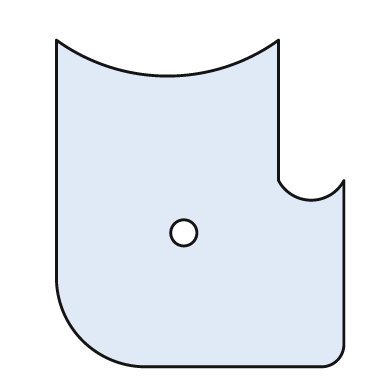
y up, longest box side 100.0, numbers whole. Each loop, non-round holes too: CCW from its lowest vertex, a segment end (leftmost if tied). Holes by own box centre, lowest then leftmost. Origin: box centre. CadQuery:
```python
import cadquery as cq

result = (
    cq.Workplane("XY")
    .moveTo(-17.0, -50.0)
    .lineTo(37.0, -50.0)
    .threePointArc((42.0, -48.0), (44.0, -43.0))
    .lineTo(44.0, 7.0)
    .threePointArc((34.0, 1.0), (24.0, 7.0))
    .lineTo(24.0, 50.0)
    .threePointArc((-10.0, 39.0), (-44.0, 50.0))
    .lineTo(-44.0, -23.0)
    .threePointArc((-36.0, -42.0), (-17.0, -50.0))
    .close()
    .moveTo(-5.0, -9.0)
    .circle(4.0)
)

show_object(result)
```